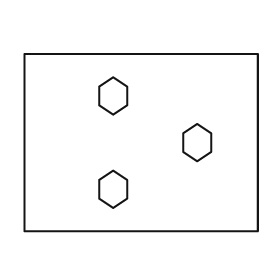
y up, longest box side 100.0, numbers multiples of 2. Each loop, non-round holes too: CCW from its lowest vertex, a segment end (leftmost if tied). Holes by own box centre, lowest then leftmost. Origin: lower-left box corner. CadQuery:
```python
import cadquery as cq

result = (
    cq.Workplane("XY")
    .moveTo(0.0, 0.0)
    .lineTo(100.0, 0.0)
    .lineTo(100.0, 76.0)
    .lineTo(0.0, 76.0)
    .close()
    .moveTo(38.0, 10.0)
    .lineTo(44.0, 14.0)
    .lineTo(44.0, 22.0)
    .lineTo(38.0, 26.0)
    .lineTo(32.0, 22.0)
    .lineTo(32.0, 14.0)
    .close()
    .moveTo(74.0, 30.0)
    .lineTo(80.0, 34.0)
    .lineTo(80.0, 42.0)
    .lineTo(74.0, 46.0)
    .lineTo(68.0, 42.0)
    .lineTo(68.0, 34.0)
    .close()
    .moveTo(38.0, 50.0)
    .lineTo(44.0, 54.0)
    .lineTo(44.0, 62.0)
    .lineTo(38.0, 66.0)
    .lineTo(32.0, 62.0)
    .lineTo(32.0, 54.0)
    .close()
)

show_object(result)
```